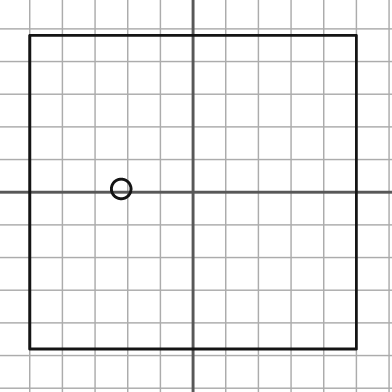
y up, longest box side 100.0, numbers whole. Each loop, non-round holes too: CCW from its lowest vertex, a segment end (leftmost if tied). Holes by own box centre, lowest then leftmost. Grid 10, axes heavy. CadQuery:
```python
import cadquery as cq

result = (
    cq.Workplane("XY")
    .moveTo(-50.0, -48.0)
    .lineTo(50.0, -48.0)
    .lineTo(50.0, 48.0)
    .lineTo(-50.0, 48.0)
    .close()
    .moveTo(-22.0, 1.0)
    .circle(3.0)
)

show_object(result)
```